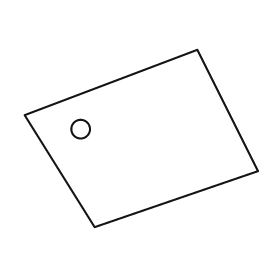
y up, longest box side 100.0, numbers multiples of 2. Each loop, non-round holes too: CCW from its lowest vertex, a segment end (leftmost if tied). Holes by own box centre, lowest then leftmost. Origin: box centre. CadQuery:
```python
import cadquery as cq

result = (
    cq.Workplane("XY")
    .moveTo(-20.0, -38.0)
    .lineTo(50.0, -14.0)
    .lineTo(24.0, 38.0)
    .lineTo(-50.0, 10.0)
    .close()
    .moveTo(-26.0, 4.0)
    .circle(4.0)
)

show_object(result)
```